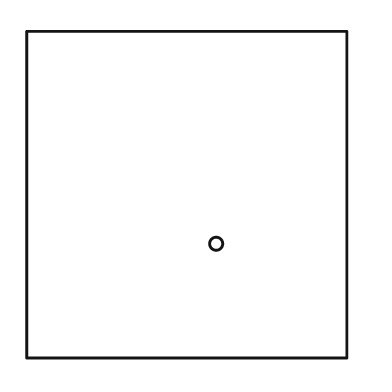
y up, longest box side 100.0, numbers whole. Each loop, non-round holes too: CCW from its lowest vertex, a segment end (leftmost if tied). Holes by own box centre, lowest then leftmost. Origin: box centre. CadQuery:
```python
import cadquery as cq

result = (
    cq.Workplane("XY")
    .moveTo(-49.0, -50.0)
    .lineTo(49.0, -50.0)
    .lineTo(49.0, 50.0)
    .lineTo(-49.0, 50.0)
    .close()
    .moveTo(9.0, -15.0)
    .circle(2.0)
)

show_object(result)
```